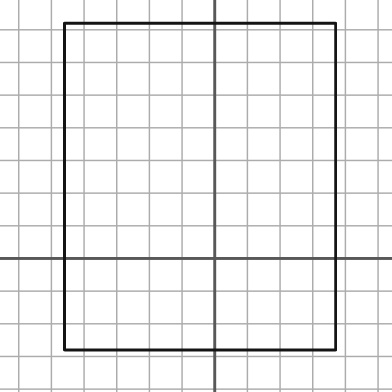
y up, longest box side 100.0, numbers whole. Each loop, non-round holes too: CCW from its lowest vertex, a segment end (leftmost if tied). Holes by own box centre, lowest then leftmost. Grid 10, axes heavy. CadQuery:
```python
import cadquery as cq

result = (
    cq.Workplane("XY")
    .moveTo(-46.0, -28.0)
    .lineTo(37.0, -28.0)
    .lineTo(37.0, 72.0)
    .lineTo(-46.0, 72.0)
    .close()
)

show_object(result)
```